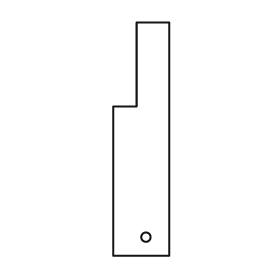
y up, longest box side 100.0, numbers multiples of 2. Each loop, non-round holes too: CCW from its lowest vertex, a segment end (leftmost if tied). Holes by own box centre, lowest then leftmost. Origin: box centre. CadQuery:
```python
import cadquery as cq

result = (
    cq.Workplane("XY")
    .moveTo(-12.0, -50.0)
    .lineTo(12.0, -50.0)
    .lineTo(12.0, 50.0)
    .lineTo(-2.0, 50.0)
    .lineTo(-2.0, 14.0)
    .lineTo(-12.0, 14.0)
    .close()
    .moveTo(2.0, -42.0)
    .circle(2.0)
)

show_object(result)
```